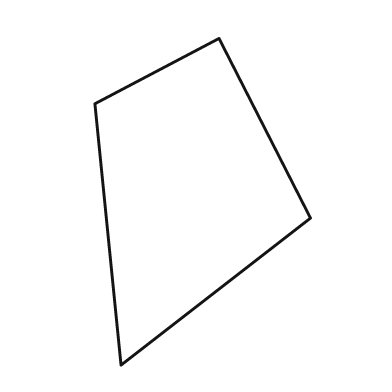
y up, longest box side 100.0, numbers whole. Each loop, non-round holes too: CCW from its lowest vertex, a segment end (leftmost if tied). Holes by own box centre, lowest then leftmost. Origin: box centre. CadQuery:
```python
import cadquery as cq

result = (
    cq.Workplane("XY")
    .moveTo(-25.0, -50.0)
    .lineTo(33.0, -5.0)
    .lineTo(5.0, 50.0)
    .lineTo(-33.0, 30.0)
    .close()
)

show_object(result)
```